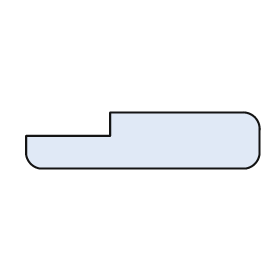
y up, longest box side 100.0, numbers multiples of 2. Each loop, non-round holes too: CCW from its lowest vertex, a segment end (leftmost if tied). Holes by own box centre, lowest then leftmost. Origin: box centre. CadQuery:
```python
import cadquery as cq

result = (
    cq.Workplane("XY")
    .moveTo(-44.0, -12.0)
    .lineTo(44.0, -12.0)
    .threePointArc((48.0, -10.0), (50.0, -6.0))
    .lineTo(50.0, 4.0)
    .threePointArc((48.0, 10.0), (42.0, 12.0))
    .lineTo(-14.0, 12.0)
    .lineTo(-14.0, 2.0)
    .lineTo(-50.0, 2.0)
    .lineTo(-50.0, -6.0)
    .threePointArc((-48.0, -10.0), (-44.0, -12.0))
    .close()
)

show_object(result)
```